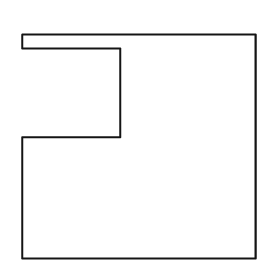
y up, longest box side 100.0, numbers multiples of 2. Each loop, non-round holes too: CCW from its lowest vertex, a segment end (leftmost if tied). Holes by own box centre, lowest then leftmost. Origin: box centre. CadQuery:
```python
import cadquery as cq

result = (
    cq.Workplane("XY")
    .moveTo(-50.0, -48.0)
    .lineTo(50.0, -48.0)
    .lineTo(50.0, 48.0)
    .lineTo(-50.0, 48.0)
    .lineTo(-50.0, 42.0)
    .lineTo(-8.0, 42.0)
    .lineTo(-8.0, 4.0)
    .lineTo(-50.0, 4.0)
    .close()
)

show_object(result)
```